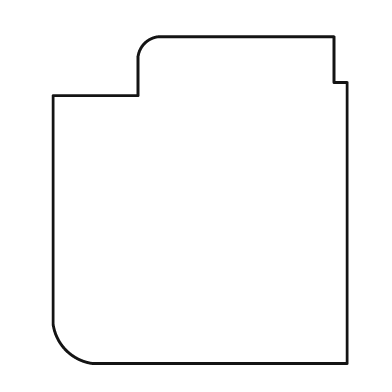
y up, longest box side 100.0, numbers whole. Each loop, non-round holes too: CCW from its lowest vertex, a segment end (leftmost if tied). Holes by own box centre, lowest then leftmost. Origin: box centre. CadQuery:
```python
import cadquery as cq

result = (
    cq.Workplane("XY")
    .moveTo(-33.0, -50.0)
    .lineTo(45.0, -50.0)
    .lineTo(45.0, 36.0)
    .lineTo(41.0, 36.0)
    .lineTo(41.0, 50.0)
    .lineTo(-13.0, 50.0)
    .threePointArc((-17.0, 48.0), (-19.0, 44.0))
    .lineTo(-19.0, 32.0)
    .lineTo(-45.0, 32.0)
    .lineTo(-45.0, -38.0)
    .threePointArc((-41.0, -46.0), (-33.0, -50.0))
    .close()
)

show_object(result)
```